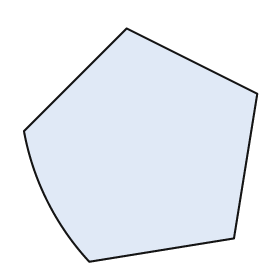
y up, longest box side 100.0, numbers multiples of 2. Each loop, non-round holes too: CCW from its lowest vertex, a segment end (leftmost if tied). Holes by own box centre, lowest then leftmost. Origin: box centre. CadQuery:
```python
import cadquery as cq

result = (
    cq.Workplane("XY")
    .moveTo(-22.0, -50.0)
    .lineTo(40.0, -40.0)
    .lineTo(50.0, 22.0)
    .lineTo(-6.0, 50.0)
    .lineTo(-50.0, 6.0)
    .threePointArc((-40.0, -24.0), (-22.0, -50.0))
    .close()
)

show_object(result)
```